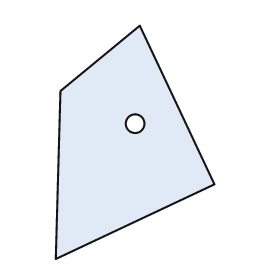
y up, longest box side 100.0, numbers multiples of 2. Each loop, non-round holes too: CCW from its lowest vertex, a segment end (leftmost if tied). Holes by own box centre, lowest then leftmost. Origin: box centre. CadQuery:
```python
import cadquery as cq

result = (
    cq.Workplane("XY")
    .moveTo(-34.0, -50.0)
    .lineTo(34.0, -18.0)
    .lineTo(2.0, 50.0)
    .lineTo(-32.0, 22.0)
    .close()
    .moveTo(0.0, 8.0)
    .circle(4.0)
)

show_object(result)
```